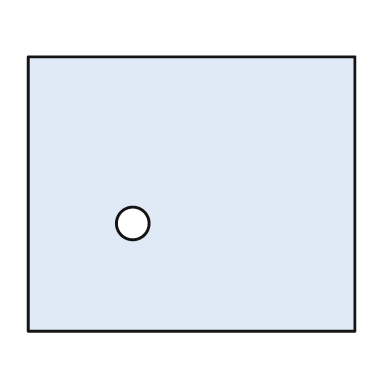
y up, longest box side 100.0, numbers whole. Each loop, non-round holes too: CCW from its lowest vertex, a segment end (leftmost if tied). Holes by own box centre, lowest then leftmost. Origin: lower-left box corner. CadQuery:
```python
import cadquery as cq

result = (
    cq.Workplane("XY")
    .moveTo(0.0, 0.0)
    .lineTo(100.0, 0.0)
    .lineTo(100.0, 84.0)
    .lineTo(0.0, 84.0)
    .close()
    .moveTo(32.0, 33.0)
    .circle(5.0)
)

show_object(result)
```